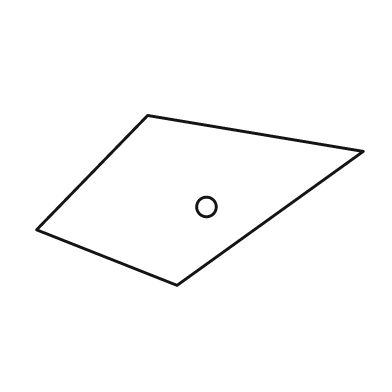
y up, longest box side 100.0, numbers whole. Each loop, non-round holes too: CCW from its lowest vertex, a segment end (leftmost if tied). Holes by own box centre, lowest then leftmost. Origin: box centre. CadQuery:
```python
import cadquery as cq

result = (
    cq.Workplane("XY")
    .moveTo(-7.0, -26.0)
    .lineTo(50.0, 15.0)
    .lineTo(-16.0, 26.0)
    .lineTo(-50.0, -9.0)
    .close()
    .moveTo(2.0, -2.0)
    .circle(3.0)
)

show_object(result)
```